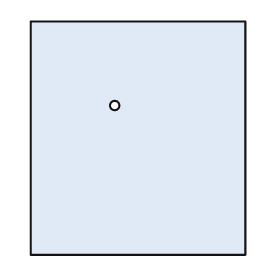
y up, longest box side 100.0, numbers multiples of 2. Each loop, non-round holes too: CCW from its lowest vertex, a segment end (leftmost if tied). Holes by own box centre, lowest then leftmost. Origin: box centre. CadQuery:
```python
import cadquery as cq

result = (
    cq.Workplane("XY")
    .moveTo(-46.0, -50.0)
    .lineTo(46.0, -50.0)
    .lineTo(46.0, 50.0)
    .lineTo(-46.0, 50.0)
    .close()
    .moveTo(-10.0, 14.0)
    .circle(2.0)
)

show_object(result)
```